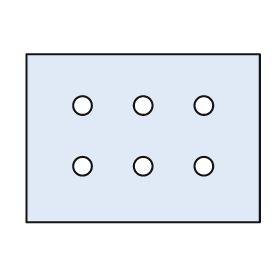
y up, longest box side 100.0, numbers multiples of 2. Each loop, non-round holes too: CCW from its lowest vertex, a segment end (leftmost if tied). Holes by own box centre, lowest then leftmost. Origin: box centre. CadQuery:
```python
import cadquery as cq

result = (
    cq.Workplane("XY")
    .moveTo(-50.0, -36.0)
    .lineTo(50.0, -36.0)
    .lineTo(50.0, 36.0)
    .lineTo(-50.0, 36.0)
    .close()
    .moveTo(-26.0, -12.0)
    .circle(4.0)
    .moveTo(0.0, -12.0)
    .circle(4.0)
    .moveTo(26.0, -12.0)
    .circle(4.0)
    .moveTo(-26.0, 14.0)
    .circle(4.0)
    .moveTo(0.0, 14.0)
    .circle(4.0)
    .moveTo(26.0, 14.0)
    .circle(4.0)
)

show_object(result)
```